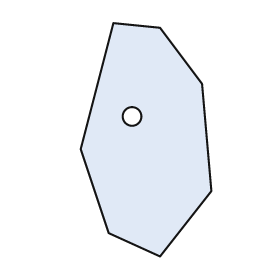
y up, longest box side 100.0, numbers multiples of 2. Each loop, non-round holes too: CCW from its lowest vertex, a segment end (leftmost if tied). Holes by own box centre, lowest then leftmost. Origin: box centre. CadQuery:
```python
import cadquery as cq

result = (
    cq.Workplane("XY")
    .moveTo(6.0, -50.0)
    .lineTo(28.0, -22.0)
    .lineTo(24.0, 24.0)
    .lineTo(6.0, 48.0)
    .lineTo(-14.0, 50.0)
    .lineTo(-28.0, -4.0)
    .lineTo(-16.0, -40.0)
    .close()
    .moveTo(-6.0, 10.0)
    .circle(4.0)
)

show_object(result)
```